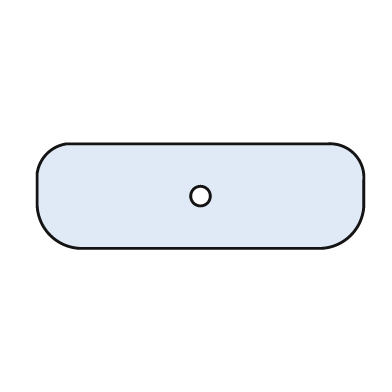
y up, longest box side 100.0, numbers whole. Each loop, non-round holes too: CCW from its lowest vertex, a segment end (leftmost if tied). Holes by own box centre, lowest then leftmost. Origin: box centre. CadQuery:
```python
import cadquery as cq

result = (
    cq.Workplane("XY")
    .moveTo(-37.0, -16.0)
    .lineTo(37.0, -16.0)
    .threePointArc((46.0, -12.0), (50.0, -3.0))
    .lineTo(50.0, 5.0)
    .threePointArc((47.0, 13.0), (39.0, 16.0))
    .lineTo(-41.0, 16.0)
    .threePointArc((-47.0, 13.0), (-50.0, 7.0))
    .lineTo(-50.0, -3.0)
    .threePointArc((-46.0, -12.0), (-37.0, -16.0))
    .close()
    .moveTo(0.0, 0.0)
    .circle(3.0)
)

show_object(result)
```